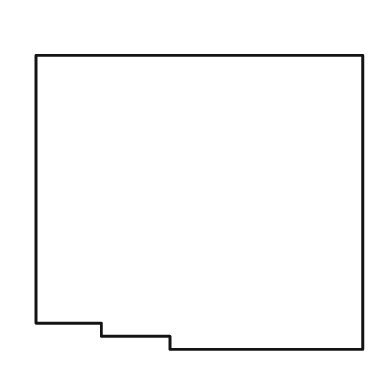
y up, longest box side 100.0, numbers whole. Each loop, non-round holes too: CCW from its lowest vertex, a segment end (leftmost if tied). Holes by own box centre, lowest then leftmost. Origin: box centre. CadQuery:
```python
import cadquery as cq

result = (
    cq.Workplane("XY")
    .moveTo(-9.0, -45.0)
    .lineTo(50.0, -45.0)
    .lineTo(50.0, 45.0)
    .lineTo(-50.0, 45.0)
    .lineTo(-50.0, -37.0)
    .lineTo(-30.0, -37.0)
    .lineTo(-30.0, -41.0)
    .lineTo(-9.0, -41.0)
    .close()
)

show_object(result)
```